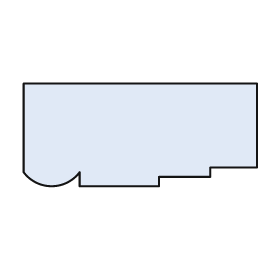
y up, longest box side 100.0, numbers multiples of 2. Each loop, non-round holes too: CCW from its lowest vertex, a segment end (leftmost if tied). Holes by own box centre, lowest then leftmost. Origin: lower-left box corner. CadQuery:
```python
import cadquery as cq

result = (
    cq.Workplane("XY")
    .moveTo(24.0, 0.0)
    .lineTo(58.0, 0.0)
    .lineTo(58.0, 4.0)
    .lineTo(80.0, 4.0)
    .lineTo(80.0, 8.0)
    .lineTo(100.0, 8.0)
    .lineTo(100.0, 44.0)
    .lineTo(0.0, 44.0)
    .lineTo(0.0, 6.0)
    .threePointArc((12.0, 0.0), (24.0, 6.0))
    .close()
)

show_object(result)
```